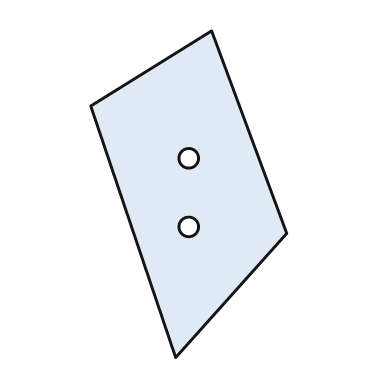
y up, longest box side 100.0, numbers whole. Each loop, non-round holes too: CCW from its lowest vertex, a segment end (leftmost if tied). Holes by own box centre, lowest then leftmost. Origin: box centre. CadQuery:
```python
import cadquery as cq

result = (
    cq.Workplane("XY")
    .moveTo(-4.0, -50.0)
    .lineTo(30.0, -12.0)
    .lineTo(7.0, 50.0)
    .lineTo(-30.0, 27.0)
    .close()
    .moveTo(0.0, -10.0)
    .circle(3.0)
    .moveTo(0.0, 11.0)
    .circle(3.0)
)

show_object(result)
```